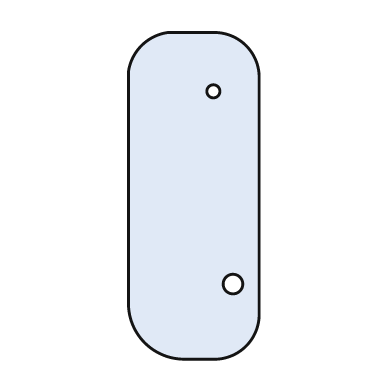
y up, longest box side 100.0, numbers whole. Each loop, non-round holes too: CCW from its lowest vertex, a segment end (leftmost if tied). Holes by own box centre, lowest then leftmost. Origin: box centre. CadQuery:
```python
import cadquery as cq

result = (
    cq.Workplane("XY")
    .moveTo(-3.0, -50.0)
    .lineTo(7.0, -50.0)
    .threePointArc((16.0, -46.0), (20.0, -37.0))
    .lineTo(20.0, 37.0)
    .threePointArc((16.0, 46.0), (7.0, 50.0))
    .lineTo(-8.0, 50.0)
    .threePointArc((-16.0, 46.0), (-20.0, 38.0))
    .lineTo(-20.0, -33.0)
    .threePointArc((-15.0, -45.0), (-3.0, -50.0))
    .close()
    .moveTo(12.0, -27.0)
    .circle(3.0)
    .moveTo(6.0, 32.0)
    .circle(2.0)
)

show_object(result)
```